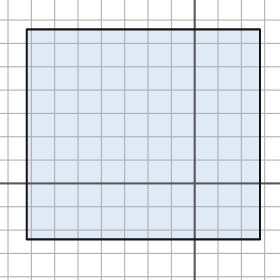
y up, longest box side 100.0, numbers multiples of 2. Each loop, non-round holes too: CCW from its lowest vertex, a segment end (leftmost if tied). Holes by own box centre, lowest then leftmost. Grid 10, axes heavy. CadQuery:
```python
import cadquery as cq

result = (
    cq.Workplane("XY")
    .moveTo(-72.0, -24.0)
    .lineTo(28.0, -24.0)
    .lineTo(28.0, 66.0)
    .lineTo(-72.0, 66.0)
    .close()
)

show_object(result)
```